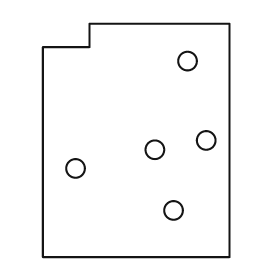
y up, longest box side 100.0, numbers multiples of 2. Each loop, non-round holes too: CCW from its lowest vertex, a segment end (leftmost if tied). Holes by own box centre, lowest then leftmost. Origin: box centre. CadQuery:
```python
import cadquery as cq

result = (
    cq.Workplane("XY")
    .moveTo(-40.0, -50.0)
    .lineTo(40.0, -50.0)
    .lineTo(40.0, 50.0)
    .lineTo(-20.0, 50.0)
    .lineTo(-20.0, 40.0)
    .lineTo(-40.0, 40.0)
    .close()
    .moveTo(16.0, -30.0)
    .circle(4.0)
    .moveTo(-26.0, -12.0)
    .circle(4.0)
    .moveTo(8.0, -4.0)
    .circle(4.0)
    .moveTo(30.0, 0.0)
    .circle(4.0)
    .moveTo(22.0, 34.0)
    .circle(4.0)
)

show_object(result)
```